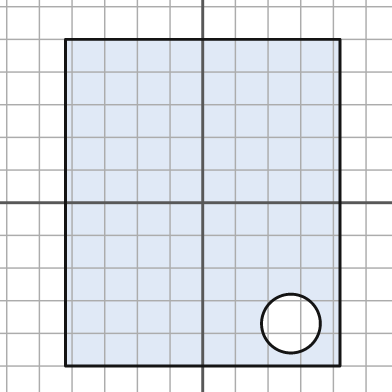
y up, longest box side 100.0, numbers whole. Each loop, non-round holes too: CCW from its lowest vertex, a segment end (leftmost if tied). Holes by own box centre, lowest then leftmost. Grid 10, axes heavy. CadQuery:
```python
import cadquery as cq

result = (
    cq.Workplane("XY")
    .moveTo(-42.0, -50.0)
    .lineTo(42.0, -50.0)
    .lineTo(42.0, 50.0)
    .lineTo(-42.0, 50.0)
    .close()
    .moveTo(27.0, -37.0)
    .circle(9.0)
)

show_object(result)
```